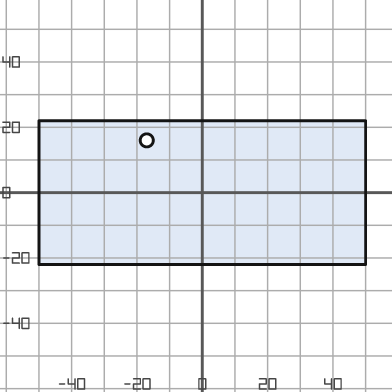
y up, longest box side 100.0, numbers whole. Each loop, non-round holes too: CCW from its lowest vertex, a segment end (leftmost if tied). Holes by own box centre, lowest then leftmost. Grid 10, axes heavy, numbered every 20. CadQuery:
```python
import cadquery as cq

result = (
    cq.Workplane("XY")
    .moveTo(-50.0, -22.0)
    .lineTo(50.0, -22.0)
    .lineTo(50.0, 22.0)
    .lineTo(-50.0, 22.0)
    .close()
    .moveTo(-17.0, 16.0)
    .circle(2.0)
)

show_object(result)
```